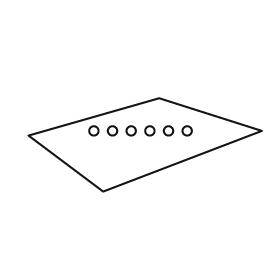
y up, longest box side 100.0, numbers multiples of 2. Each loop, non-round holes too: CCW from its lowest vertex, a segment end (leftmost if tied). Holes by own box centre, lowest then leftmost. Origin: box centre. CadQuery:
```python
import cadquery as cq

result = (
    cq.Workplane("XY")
    .moveTo(-18.0, -20.0)
    .lineTo(50.0, 6.0)
    .lineTo(6.0, 20.0)
    .lineTo(-50.0, 4.0)
    .close()
    .moveTo(-22.0, 6.0)
    .circle(2.0)
    .moveTo(-14.0, 6.0)
    .circle(2.0)
    .moveTo(-6.0, 6.0)
    .circle(2.0)
    .moveTo(2.0, 6.0)
    .circle(2.0)
    .moveTo(10.0, 6.0)
    .circle(2.0)
    .moveTo(18.0, 6.0)
    .circle(2.0)
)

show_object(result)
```